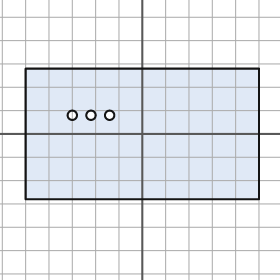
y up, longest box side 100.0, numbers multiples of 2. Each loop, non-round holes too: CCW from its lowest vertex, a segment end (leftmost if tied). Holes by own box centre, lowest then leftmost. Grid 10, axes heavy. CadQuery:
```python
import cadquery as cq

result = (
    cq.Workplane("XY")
    .moveTo(-50.0, -28.0)
    .lineTo(50.0, -28.0)
    .lineTo(50.0, 28.0)
    .lineTo(-50.0, 28.0)
    .close()
    .moveTo(-30.0, 8.0)
    .circle(2.0)
    .moveTo(-22.0, 8.0)
    .circle(2.0)
    .moveTo(-14.0, 8.0)
    .circle(2.0)
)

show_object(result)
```